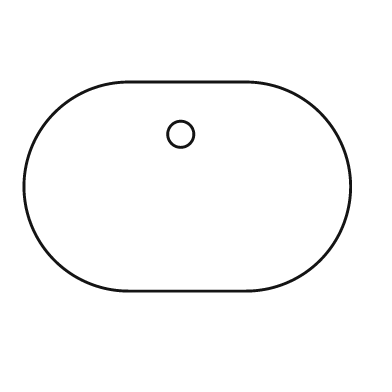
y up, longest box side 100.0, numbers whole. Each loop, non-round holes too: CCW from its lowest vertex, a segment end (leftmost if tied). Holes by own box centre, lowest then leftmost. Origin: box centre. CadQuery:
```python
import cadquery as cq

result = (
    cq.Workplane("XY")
    .moveTo(-18.0, -32.0)
    .lineTo(18.0, -32.0)
    .threePointArc((50.0, 0.0), (18.0, 32.0))
    .lineTo(-18.0, 32.0)
    .threePointArc((-50.0, 0.0), (-18.0, -32.0))
    .close()
    .moveTo(-2.0, 16.0)
    .circle(4.0)
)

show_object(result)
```